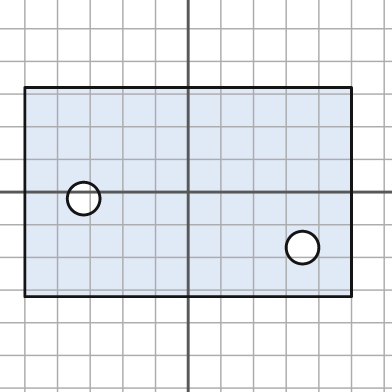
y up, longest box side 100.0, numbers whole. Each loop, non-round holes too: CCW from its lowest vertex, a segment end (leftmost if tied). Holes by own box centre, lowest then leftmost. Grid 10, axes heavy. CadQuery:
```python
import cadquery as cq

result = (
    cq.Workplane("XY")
    .moveTo(-50.0, -32.0)
    .lineTo(50.0, -32.0)
    .lineTo(50.0, 32.0)
    .lineTo(-50.0, 32.0)
    .close()
    .moveTo(35.0, -17.0)
    .circle(5.0)
    .moveTo(-32.0, -2.0)
    .circle(5.0)
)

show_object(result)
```